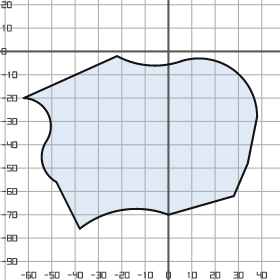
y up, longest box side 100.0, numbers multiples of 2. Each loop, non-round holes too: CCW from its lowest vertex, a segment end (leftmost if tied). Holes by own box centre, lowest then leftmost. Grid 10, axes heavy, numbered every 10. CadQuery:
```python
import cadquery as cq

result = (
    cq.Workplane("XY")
    .moveTo(-38.0, -76.0)
    .threePointArc((-20.0, -68.0), (0.0, -70.0))
    .lineTo(28.0, -62.0)
    .lineTo(34.0, -48.0)
    .lineTo(38.0, -28.0)
    .threePointArc((28.0, -8.0), (6.0, -4.0))
    .threePointArc((-8.0, -6.0), (-22.0, -2.0))
    .lineTo(-62.0, -20.0)
    .threePointArc((-52.0, -26.0), (-52.0, -38.0))
    .threePointArc((-54.0, -48.0), (-48.0, -56.0))
    .close()
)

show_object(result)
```